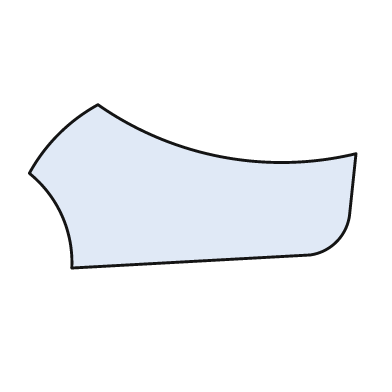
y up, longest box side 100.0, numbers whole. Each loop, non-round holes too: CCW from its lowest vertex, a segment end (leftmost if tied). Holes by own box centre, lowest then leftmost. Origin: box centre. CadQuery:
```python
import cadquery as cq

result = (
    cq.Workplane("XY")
    .moveTo(-37.0, -25.0)
    .lineTo(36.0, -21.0)
    .threePointArc((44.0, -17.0), (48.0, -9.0))
    .lineTo(50.0, 10.0)
    .threePointArc((9.0, 9.0), (-29.0, 25.0))
    .threePointArc((-41.0, 16.0), (-50.0, 4.0))
    .threePointArc((-40.0, -9.0), (-37.0, -25.0))
    .close()
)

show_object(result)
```